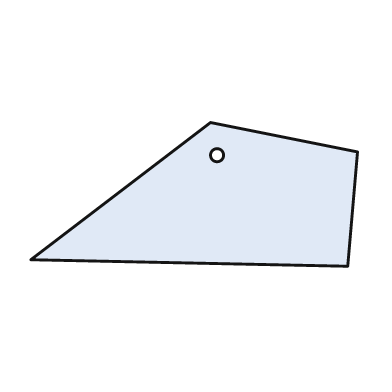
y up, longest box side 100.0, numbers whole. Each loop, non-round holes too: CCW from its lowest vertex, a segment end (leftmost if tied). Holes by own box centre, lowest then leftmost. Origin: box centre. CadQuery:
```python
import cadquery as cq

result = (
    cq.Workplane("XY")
    .moveTo(47.0, -22.0)
    .lineTo(50.0, 13.0)
    .lineTo(5.0, 22.0)
    .lineTo(-50.0, -20.0)
    .close()
    .moveTo(7.0, 12.0)
    .circle(2.0)
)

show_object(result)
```